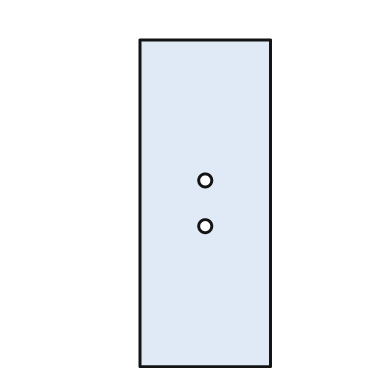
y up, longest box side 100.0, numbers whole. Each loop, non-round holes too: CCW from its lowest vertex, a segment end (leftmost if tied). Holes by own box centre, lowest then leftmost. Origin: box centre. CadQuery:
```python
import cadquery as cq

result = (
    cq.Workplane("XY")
    .moveTo(-20.0, -50.0)
    .lineTo(20.0, -50.0)
    .lineTo(20.0, 50.0)
    .lineTo(-20.0, 50.0)
    .close()
    .moveTo(0.0, -7.0)
    .circle(2.0)
    .moveTo(0.0, 7.0)
    .circle(2.0)
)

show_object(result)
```